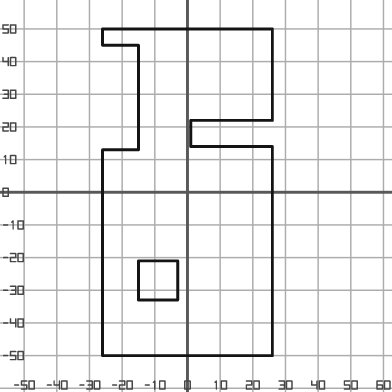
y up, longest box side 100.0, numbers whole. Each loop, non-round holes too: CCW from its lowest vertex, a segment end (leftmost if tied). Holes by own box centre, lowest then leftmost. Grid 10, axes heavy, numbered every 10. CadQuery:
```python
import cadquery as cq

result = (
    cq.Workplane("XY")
    .moveTo(-26.0, -50.0)
    .lineTo(26.0, -50.0)
    .lineTo(26.0, 14.0)
    .lineTo(1.0, 14.0)
    .lineTo(1.0, 22.0)
    .lineTo(26.0, 22.0)
    .lineTo(26.0, 50.0)
    .lineTo(-26.0, 50.0)
    .lineTo(-26.0, 45.0)
    .lineTo(-15.0, 45.0)
    .lineTo(-15.0, 13.0)
    .lineTo(-26.0, 13.0)
    .close()
    .moveTo(-15.0, -33.0)
    .lineTo(-3.0, -33.0)
    .lineTo(-3.0, -21.0)
    .lineTo(-15.0, -21.0)
    .close()
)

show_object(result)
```